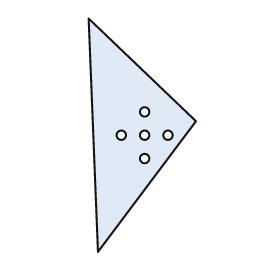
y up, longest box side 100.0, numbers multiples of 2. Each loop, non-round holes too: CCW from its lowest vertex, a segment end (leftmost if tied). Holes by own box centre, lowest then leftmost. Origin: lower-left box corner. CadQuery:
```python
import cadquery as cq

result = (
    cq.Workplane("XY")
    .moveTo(4.0, 0.0)
    .lineTo(46.0, 56.0)
    .lineTo(0.0, 100.0)
    .close()
    .moveTo(24.0, 40.0)
    .circle(2.0)
    .moveTo(14.0, 50.0)
    .circle(2.0)
    .moveTo(24.0, 50.0)
    .circle(2.0)
    .moveTo(34.0, 50.0)
    .circle(2.0)
    .moveTo(24.0, 60.0)
    .circle(2.0)
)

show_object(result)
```